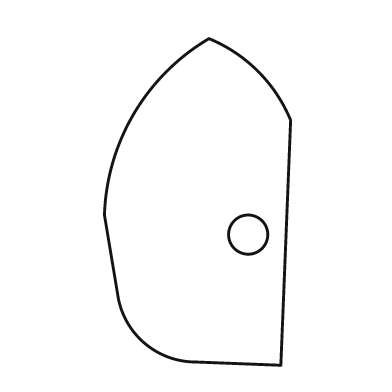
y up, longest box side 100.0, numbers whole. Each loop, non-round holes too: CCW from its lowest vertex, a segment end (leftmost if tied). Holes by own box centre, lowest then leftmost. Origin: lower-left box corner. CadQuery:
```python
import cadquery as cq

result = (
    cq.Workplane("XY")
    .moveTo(54.0, 0.0)
    .lineTo(57.0, 75.0)
    .threePointArc((47.0, 90.0), (32.0, 100.0))
    .threePointArc((9.0, 77.0), (0.0, 46.0))
    .lineTo(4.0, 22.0)
    .threePointArc((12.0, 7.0), (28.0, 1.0))
    .close()
    .moveTo(44.0, 40.0)
    .circle(6.0)
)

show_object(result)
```